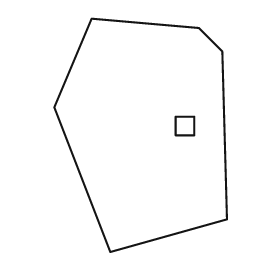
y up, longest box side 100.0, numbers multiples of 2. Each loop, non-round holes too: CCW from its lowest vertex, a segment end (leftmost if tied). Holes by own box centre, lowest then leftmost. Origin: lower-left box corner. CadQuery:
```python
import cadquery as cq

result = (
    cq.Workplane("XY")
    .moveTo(24.0, 0.0)
    .lineTo(74.0, 14.0)
    .lineTo(72.0, 86.0)
    .lineTo(62.0, 96.0)
    .lineTo(16.0, 100.0)
    .lineTo(0.0, 62.0)
    .close()
    .moveTo(52.0, 50.0)
    .lineTo(60.0, 50.0)
    .lineTo(60.0, 58.0)
    .lineTo(52.0, 58.0)
    .close()
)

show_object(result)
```